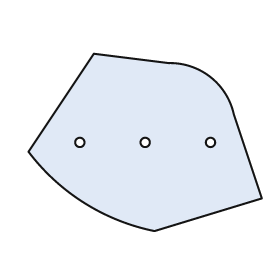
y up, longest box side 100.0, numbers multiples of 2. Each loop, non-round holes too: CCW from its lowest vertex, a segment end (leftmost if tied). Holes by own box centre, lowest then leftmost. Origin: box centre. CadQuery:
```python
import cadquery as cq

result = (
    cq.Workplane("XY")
    .moveTo(4.0, -38.0)
    .lineTo(50.0, -24.0)
    .lineTo(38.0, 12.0)
    .threePointArc((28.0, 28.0), (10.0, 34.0))
    .lineTo(-22.0, 38.0)
    .lineTo(-50.0, -4.0)
    .threePointArc((-26.0, -26.0), (4.0, -38.0))
    .close()
    .moveTo(-28.0, 0.0)
    .circle(2.0)
    .moveTo(0.0, 0.0)
    .circle(2.0)
    .moveTo(28.0, 0.0)
    .circle(2.0)
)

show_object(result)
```